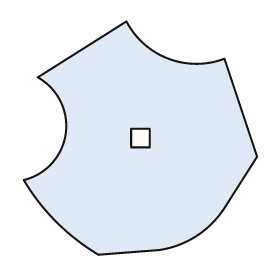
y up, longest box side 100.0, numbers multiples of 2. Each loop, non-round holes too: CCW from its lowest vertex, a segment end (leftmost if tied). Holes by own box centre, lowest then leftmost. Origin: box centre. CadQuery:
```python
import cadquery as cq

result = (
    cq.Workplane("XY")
    .moveTo(-18.0, -50.0)
    .lineTo(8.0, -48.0)
    .threePointArc((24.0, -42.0), (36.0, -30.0))
    .lineTo(50.0, -8.0)
    .lineTo(36.0, 34.0)
    .threePointArc((12.0, 34.0), (-6.0, 50.0))
    .lineTo(-44.0, 26.0)
    .threePointArc((-32.0, 2.0), (-50.0, -18.0))
    .threePointArc((-36.0, -36.0), (-18.0, -50.0))
    .close()
    .moveTo(-4.0, -4.0)
    .lineTo(4.0, -4.0)
    .lineTo(4.0, 4.0)
    .lineTo(-4.0, 4.0)
    .close()
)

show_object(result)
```